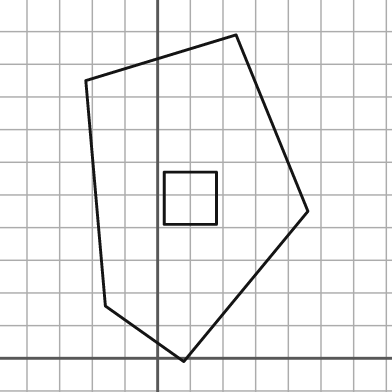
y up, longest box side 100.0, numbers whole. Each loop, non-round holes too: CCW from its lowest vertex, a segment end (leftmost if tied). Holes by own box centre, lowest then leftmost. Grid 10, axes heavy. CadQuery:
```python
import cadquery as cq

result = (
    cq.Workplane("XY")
    .moveTo(8.0, -1.0)
    .lineTo(46.0, 45.0)
    .lineTo(24.0, 99.0)
    .lineTo(-22.0, 85.0)
    .lineTo(-16.0, 16.0)
    .close()
    .moveTo(2.0, 41.0)
    .lineTo(18.0, 41.0)
    .lineTo(18.0, 57.0)
    .lineTo(2.0, 57.0)
    .close()
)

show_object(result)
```